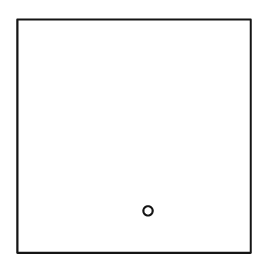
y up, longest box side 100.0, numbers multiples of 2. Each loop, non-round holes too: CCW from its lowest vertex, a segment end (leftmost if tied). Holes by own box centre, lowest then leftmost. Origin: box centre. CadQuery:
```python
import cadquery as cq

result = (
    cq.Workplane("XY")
    .moveTo(-50.0, -50.0)
    .lineTo(50.0, -50.0)
    .lineTo(50.0, 50.0)
    .lineTo(-50.0, 50.0)
    .close()
    .moveTo(6.0, -32.0)
    .circle(2.0)
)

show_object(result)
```